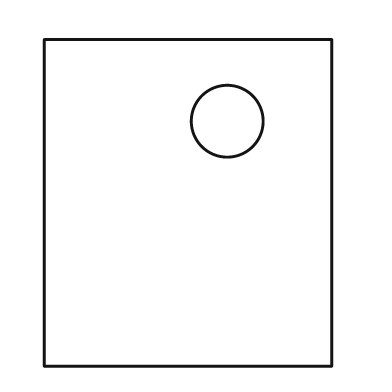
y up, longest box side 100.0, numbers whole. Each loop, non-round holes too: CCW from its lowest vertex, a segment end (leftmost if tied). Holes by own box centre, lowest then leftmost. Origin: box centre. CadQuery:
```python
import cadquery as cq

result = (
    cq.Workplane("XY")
    .moveTo(-44.0, -50.0)
    .lineTo(44.0, -50.0)
    .lineTo(44.0, 50.0)
    .lineTo(-44.0, 50.0)
    .close()
    .moveTo(12.0, 25.0)
    .circle(11.0)
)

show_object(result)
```